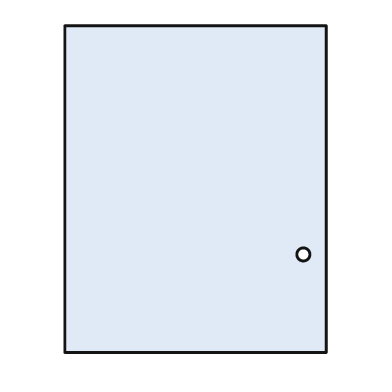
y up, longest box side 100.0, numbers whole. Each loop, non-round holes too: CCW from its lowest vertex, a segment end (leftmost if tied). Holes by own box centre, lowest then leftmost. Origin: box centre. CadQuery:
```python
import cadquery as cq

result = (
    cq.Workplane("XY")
    .moveTo(-40.0, -50.0)
    .lineTo(40.0, -50.0)
    .lineTo(40.0, 50.0)
    .lineTo(-40.0, 50.0)
    .close()
    .moveTo(33.0, -20.0)
    .circle(2.0)
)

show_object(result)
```